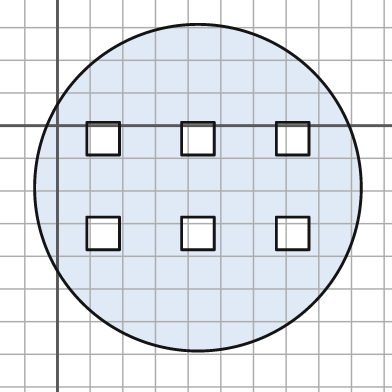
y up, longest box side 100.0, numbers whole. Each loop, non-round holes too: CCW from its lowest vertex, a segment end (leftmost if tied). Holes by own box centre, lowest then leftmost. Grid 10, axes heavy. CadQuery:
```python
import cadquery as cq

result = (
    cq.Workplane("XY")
    .moveTo(43.0, -19.0)
    .circle(50.0)
    .moveTo(9.0, -38.0)
    .lineTo(19.0, -38.0)
    .lineTo(19.0, -28.0)
    .lineTo(9.0, -28.0)
    .close()
    .moveTo(38.0, -38.0)
    .lineTo(48.0, -38.0)
    .lineTo(48.0, -28.0)
    .lineTo(38.0, -28.0)
    .close()
    .moveTo(67.0, -38.0)
    .lineTo(77.0, -38.0)
    .lineTo(77.0, -28.0)
    .lineTo(67.0, -28.0)
    .close()
    .moveTo(9.0, -9.0)
    .lineTo(19.0, -9.0)
    .lineTo(19.0, 1.0)
    .lineTo(9.0, 1.0)
    .close()
    .moveTo(38.0, -9.0)
    .lineTo(48.0, -9.0)
    .lineTo(48.0, 1.0)
    .lineTo(38.0, 1.0)
    .close()
    .moveTo(67.0, -9.0)
    .lineTo(77.0, -9.0)
    .lineTo(77.0, 1.0)
    .lineTo(67.0, 1.0)
    .close()
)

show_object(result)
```